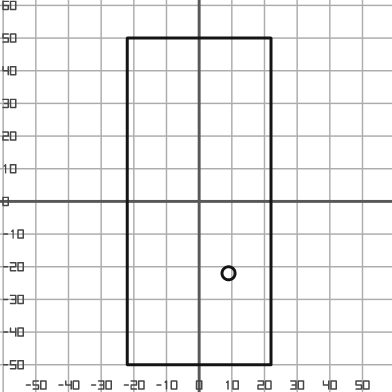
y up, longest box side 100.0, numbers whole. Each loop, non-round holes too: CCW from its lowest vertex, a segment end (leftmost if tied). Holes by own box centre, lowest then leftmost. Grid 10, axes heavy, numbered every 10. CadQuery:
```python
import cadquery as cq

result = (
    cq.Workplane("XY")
    .moveTo(-22.0, -50.0)
    .lineTo(22.0, -50.0)
    .lineTo(22.0, 50.0)
    .lineTo(-22.0, 50.0)
    .close()
    .moveTo(9.0, -22.0)
    .circle(2.0)
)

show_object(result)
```